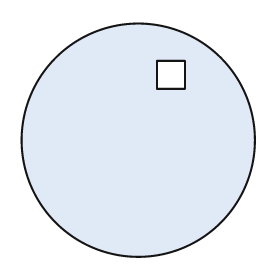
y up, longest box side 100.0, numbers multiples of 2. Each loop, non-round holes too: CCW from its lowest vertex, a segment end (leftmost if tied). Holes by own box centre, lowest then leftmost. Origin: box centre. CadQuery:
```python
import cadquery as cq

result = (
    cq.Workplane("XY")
    .moveTo(0.0, 0.0)
    .circle(50.0)
    .moveTo(8.0, 22.0)
    .lineTo(20.0, 22.0)
    .lineTo(20.0, 34.0)
    .lineTo(8.0, 34.0)
    .close()
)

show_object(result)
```